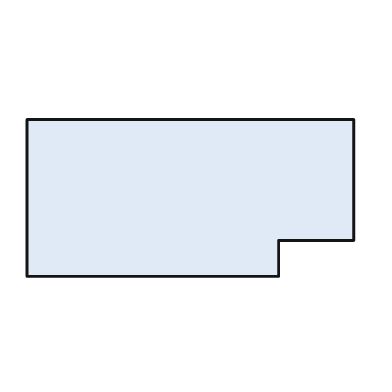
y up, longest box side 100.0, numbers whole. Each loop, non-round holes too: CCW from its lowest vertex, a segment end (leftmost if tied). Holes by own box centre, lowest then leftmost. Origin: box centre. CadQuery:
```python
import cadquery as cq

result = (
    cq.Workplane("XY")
    .moveTo(-50.0, -24.0)
    .lineTo(27.0, -24.0)
    .lineTo(27.0, -13.0)
    .lineTo(50.0, -13.0)
    .lineTo(50.0, 24.0)
    .lineTo(-50.0, 24.0)
    .close()
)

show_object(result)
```